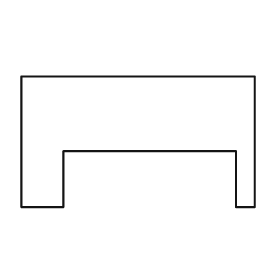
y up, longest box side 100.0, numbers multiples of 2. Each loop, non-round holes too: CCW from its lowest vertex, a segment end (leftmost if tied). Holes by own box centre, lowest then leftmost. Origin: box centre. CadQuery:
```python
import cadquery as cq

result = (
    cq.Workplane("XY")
    .moveTo(-50.0, -28.0)
    .lineTo(-32.0, -28.0)
    .lineTo(-32.0, -4.0)
    .lineTo(42.0, -4.0)
    .lineTo(42.0, -28.0)
    .lineTo(50.0, -28.0)
    .lineTo(50.0, 28.0)
    .lineTo(-50.0, 28.0)
    .close()
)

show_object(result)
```